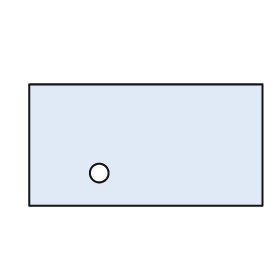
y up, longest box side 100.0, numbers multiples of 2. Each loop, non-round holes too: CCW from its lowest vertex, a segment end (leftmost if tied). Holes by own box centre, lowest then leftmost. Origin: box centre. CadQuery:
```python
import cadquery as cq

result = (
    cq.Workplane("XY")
    .moveTo(-50.0, -26.0)
    .lineTo(50.0, -26.0)
    .lineTo(50.0, 26.0)
    .lineTo(-50.0, 26.0)
    .close()
    .moveTo(-20.0, -12.0)
    .circle(4.0)
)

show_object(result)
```